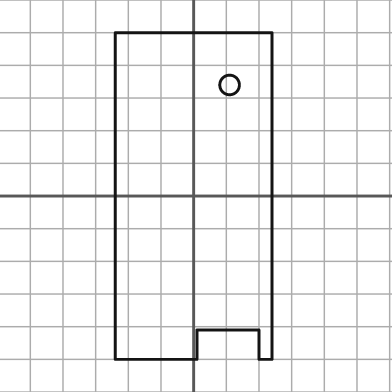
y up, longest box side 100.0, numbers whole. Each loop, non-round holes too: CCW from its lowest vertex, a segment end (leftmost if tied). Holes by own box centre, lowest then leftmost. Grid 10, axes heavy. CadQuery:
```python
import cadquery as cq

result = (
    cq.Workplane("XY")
    .moveTo(-24.0, -50.0)
    .lineTo(1.0, -50.0)
    .lineTo(1.0, -41.0)
    .lineTo(20.0, -41.0)
    .lineTo(20.0, -50.0)
    .lineTo(24.0, -50.0)
    .lineTo(24.0, 50.0)
    .lineTo(-24.0, 50.0)
    .close()
    .moveTo(11.0, 34.0)
    .circle(3.0)
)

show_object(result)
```